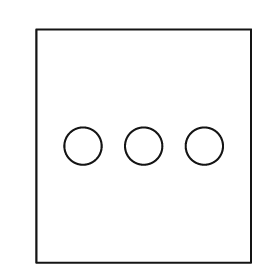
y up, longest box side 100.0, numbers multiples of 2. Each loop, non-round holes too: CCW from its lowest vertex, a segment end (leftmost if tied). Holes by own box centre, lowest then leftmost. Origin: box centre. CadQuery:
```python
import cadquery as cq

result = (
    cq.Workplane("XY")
    .moveTo(-46.0, -50.0)
    .lineTo(46.0, -50.0)
    .lineTo(46.0, 50.0)
    .lineTo(-46.0, 50.0)
    .close()
    .moveTo(-26.0, 0.0)
    .circle(8.0)
    .moveTo(0.0, 0.0)
    .circle(8.0)
    .moveTo(26.0, 0.0)
    .circle(8.0)
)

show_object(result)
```